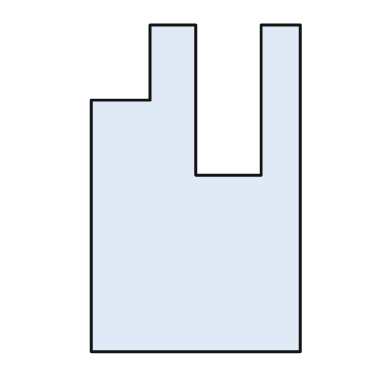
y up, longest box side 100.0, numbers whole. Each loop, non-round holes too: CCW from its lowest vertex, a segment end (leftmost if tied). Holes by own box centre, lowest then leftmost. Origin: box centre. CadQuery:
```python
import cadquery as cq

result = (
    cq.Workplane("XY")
    .moveTo(-32.0, -50.0)
    .lineTo(32.0, -50.0)
    .lineTo(32.0, 50.0)
    .lineTo(20.0, 50.0)
    .lineTo(20.0, 4.0)
    .lineTo(0.0, 4.0)
    .lineTo(0.0, 50.0)
    .lineTo(-14.0, 50.0)
    .lineTo(-14.0, 27.0)
    .lineTo(-32.0, 27.0)
    .close()
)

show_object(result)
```